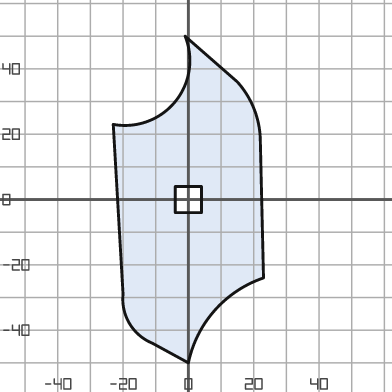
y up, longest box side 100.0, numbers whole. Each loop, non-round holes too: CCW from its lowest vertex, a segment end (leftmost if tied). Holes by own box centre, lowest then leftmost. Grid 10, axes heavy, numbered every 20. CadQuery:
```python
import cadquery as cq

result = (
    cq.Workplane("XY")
    .moveTo(0.0, -50.0)
    .threePointArc((8.0, -34.0), (23.0, -24.0))
    .lineTo(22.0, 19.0)
    .threePointArc((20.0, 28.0), (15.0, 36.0))
    .lineTo(-1.0, 50.0)
    .threePointArc((-4.0, 30.0), (-23.0, 23.0))
    .lineTo(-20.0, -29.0)
    .threePointArc((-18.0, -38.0), (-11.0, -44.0))
    .close()
    .moveTo(-4.0, -4.0)
    .lineTo(4.0, -4.0)
    .lineTo(4.0, 4.0)
    .lineTo(-4.0, 4.0)
    .close()
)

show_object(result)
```